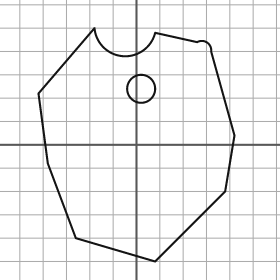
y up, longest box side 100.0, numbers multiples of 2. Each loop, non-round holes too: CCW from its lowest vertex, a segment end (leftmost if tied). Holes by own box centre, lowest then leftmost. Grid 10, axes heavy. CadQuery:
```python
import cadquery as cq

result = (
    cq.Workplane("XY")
    .moveTo(8.0, -50.0)
    .lineTo(38.0, -20.0)
    .lineTo(42.0, 4.0)
    .lineTo(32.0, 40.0)
    .threePointArc((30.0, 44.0), (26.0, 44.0))
    .lineTo(8.0, 48.0)
    .threePointArc((-6.0, 38.0), (-18.0, 50.0))
    .lineTo(-42.0, 22.0)
    .lineTo(-38.0, -8.0)
    .lineTo(-26.0, -40.0)
    .close()
    .moveTo(2.0, 24.0)
    .circle(6.0)
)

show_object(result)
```